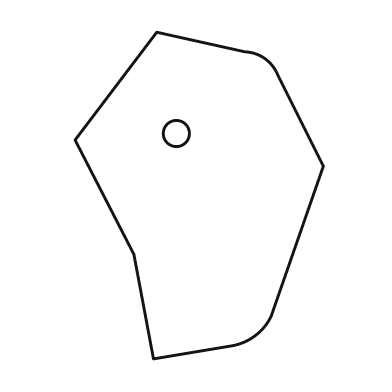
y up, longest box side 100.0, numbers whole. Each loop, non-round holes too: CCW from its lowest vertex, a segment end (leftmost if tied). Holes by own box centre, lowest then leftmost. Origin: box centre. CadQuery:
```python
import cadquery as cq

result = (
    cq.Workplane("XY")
    .moveTo(-14.0, -50.0)
    .lineTo(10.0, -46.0)
    .threePointArc((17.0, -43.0), (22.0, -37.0))
    .lineTo(38.0, 9.0)
    .lineTo(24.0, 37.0)
    .threePointArc((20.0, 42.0), (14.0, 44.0))
    .lineTo(-13.0, 50.0)
    .lineTo(-38.0, 17.0)
    .lineTo(-20.0, -18.0)
    .close()
    .moveTo(-7.0, 19.0)
    .circle(4.0)
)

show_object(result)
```